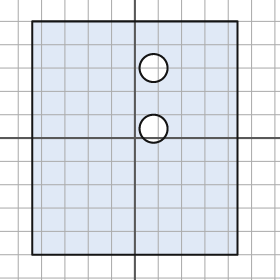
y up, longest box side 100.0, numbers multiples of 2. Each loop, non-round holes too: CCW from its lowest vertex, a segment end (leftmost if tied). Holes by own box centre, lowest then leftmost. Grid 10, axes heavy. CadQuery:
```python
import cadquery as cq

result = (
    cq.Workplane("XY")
    .moveTo(-44.0, -50.0)
    .lineTo(44.0, -50.0)
    .lineTo(44.0, 50.0)
    .lineTo(-44.0, 50.0)
    .close()
    .moveTo(8.0, 4.0)
    .circle(6.0)
    .moveTo(8.0, 30.0)
    .circle(6.0)
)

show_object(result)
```